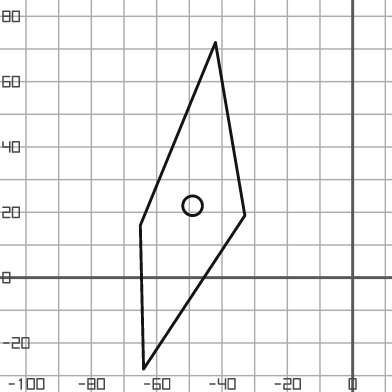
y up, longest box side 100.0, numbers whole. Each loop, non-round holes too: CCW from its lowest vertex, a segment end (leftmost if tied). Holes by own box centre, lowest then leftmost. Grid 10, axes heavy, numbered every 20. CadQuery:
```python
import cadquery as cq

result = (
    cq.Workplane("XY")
    .moveTo(-64.0, -28.0)
    .lineTo(-33.0, 19.0)
    .lineTo(-42.0, 72.0)
    .lineTo(-65.0, 16.0)
    .close()
    .moveTo(-49.0, 22.0)
    .circle(3.0)
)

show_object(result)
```